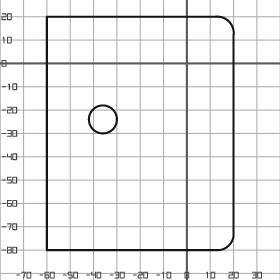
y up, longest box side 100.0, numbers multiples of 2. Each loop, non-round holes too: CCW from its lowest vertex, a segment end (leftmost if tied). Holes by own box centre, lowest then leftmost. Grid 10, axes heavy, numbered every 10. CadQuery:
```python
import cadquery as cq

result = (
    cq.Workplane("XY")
    .moveTo(-60.0, -80.0)
    .lineTo(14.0, -80.0)
    .threePointArc((18.0, -78.0), (20.0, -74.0))
    .lineTo(20.0, 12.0)
    .threePointArc((18.0, 18.0), (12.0, 20.0))
    .lineTo(-60.0, 20.0)
    .close()
    .moveTo(-36.0, -24.0)
    .circle(6.0)
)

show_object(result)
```